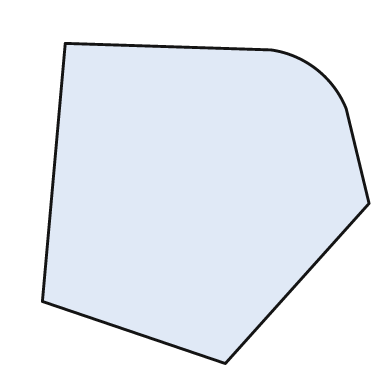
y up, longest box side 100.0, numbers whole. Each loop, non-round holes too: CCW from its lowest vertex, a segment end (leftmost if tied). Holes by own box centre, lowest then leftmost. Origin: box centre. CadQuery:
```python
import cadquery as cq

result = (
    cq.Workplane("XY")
    .moveTo(6.0, -49.0)
    .lineTo(50.0, 0.0)
    .lineTo(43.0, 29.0)
    .threePointArc((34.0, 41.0), (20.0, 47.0))
    .lineTo(-43.0, 49.0)
    .lineTo(-50.0, -30.0)
    .close()
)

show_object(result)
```